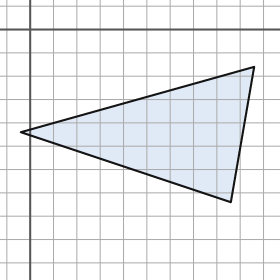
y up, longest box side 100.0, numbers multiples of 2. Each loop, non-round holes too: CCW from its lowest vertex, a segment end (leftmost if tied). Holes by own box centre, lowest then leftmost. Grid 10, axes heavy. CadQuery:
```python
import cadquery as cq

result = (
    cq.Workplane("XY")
    .moveTo(86.0, -74.0)
    .lineTo(96.0, -16.0)
    .lineTo(-4.0, -44.0)
    .close()
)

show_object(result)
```